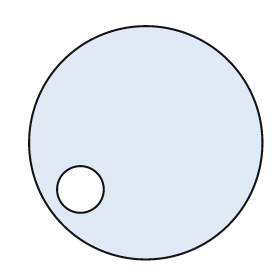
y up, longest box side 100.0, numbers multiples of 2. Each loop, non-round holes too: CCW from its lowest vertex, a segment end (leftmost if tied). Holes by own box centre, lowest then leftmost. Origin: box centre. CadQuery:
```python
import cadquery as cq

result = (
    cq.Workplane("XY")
    .moveTo(0.0, 0.0)
    .circle(50.0)
    .moveTo(-28.0, -20.0)
    .circle(10.0)
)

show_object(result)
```